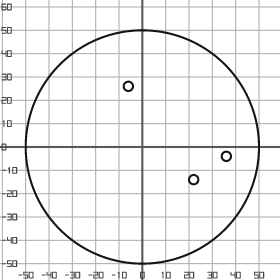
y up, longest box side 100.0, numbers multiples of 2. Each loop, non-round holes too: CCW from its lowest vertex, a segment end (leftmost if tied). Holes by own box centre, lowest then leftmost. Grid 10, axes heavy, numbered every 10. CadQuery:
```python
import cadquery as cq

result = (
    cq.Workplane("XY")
    .moveTo(0.0, 0.0)
    .circle(50.0)
    .moveTo(22.0, -14.0)
    .circle(2.0)
    .moveTo(36.0, -4.0)
    .circle(2.0)
    .moveTo(-6.0, 26.0)
    .circle(2.0)
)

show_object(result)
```